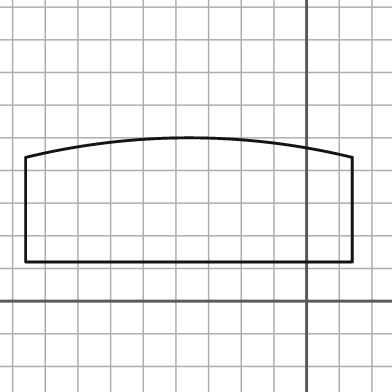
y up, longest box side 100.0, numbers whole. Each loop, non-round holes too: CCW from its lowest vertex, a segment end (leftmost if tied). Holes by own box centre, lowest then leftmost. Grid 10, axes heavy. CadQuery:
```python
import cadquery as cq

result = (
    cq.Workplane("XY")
    .moveTo(-86.0, 12.0)
    .lineTo(14.0, 12.0)
    .lineTo(14.0, 44.0)
    .threePointArc((-36.0, 50.0), (-86.0, 44.0))
    .close()
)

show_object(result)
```